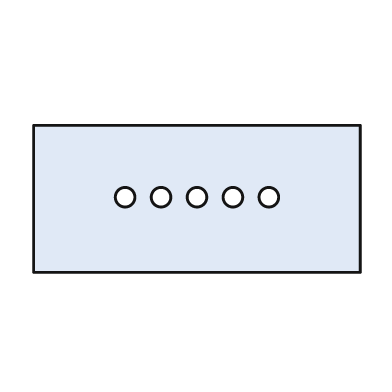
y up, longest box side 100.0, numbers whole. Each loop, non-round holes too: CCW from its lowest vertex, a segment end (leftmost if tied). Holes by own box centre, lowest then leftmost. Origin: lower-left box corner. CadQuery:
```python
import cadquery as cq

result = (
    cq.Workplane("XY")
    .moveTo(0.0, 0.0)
    .lineTo(100.0, 0.0)
    .lineTo(100.0, 45.0)
    .lineTo(0.0, 45.0)
    .close()
    .moveTo(28.0, 23.0)
    .circle(3.0)
    .moveTo(39.0, 23.0)
    .circle(3.0)
    .moveTo(50.0, 23.0)
    .circle(3.0)
    .moveTo(61.0, 23.0)
    .circle(3.0)
    .moveTo(72.0, 23.0)
    .circle(3.0)
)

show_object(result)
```